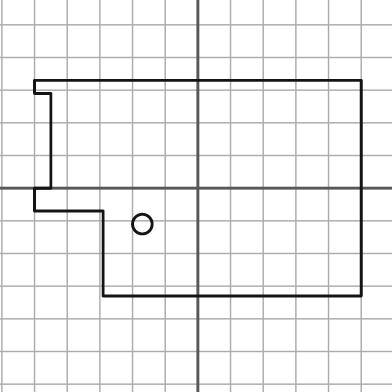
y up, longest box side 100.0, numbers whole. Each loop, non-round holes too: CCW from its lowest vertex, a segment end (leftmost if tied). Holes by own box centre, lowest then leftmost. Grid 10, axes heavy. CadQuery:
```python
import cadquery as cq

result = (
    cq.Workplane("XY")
    .moveTo(-29.0, -33.0)
    .lineTo(50.0, -33.0)
    .lineTo(50.0, 33.0)
    .lineTo(-50.0, 33.0)
    .lineTo(-50.0, 29.0)
    .lineTo(-45.0, 29.0)
    .lineTo(-45.0, 0.0)
    .lineTo(-50.0, 0.0)
    .lineTo(-50.0, -7.0)
    .lineTo(-29.0, -7.0)
    .close()
    .moveTo(-17.0, -11.0)
    .circle(3.0)
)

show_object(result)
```